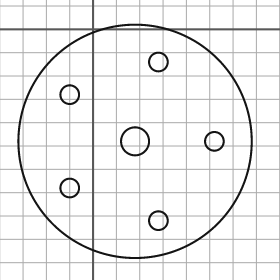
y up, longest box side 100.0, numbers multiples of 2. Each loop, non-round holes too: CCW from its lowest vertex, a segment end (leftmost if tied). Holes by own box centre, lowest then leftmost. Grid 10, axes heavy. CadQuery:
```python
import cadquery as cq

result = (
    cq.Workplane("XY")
    .moveTo(18.0, -48.0)
    .circle(50.0)
    .moveTo(28.0, -82.0)
    .circle(4.0)
    .moveTo(-10.0, -68.0)
    .circle(4.0)
    .moveTo(18.0, -48.0)
    .circle(6.0)
    .moveTo(52.0, -48.0)
    .circle(4.0)
    .moveTo(-10.0, -28.0)
    .circle(4.0)
    .moveTo(28.0, -14.0)
    .circle(4.0)
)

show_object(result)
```